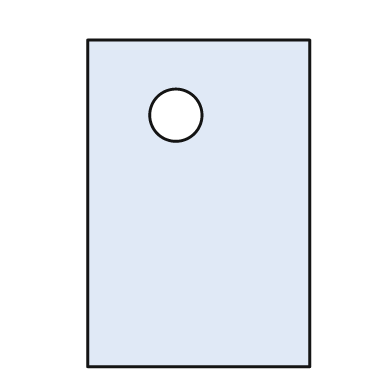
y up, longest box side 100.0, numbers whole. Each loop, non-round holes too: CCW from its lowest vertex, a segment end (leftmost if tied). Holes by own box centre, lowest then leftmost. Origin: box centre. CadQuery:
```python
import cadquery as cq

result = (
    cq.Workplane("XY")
    .moveTo(-34.0, -50.0)
    .lineTo(34.0, -50.0)
    .lineTo(34.0, 50.0)
    .lineTo(-34.0, 50.0)
    .close()
    .moveTo(-7.0, 27.0)
    .circle(8.0)
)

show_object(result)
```